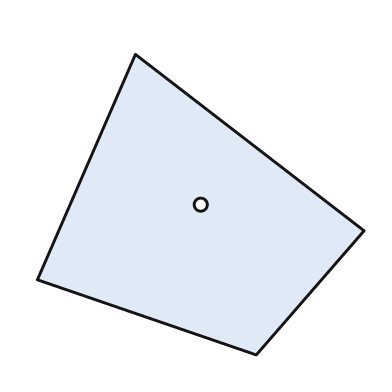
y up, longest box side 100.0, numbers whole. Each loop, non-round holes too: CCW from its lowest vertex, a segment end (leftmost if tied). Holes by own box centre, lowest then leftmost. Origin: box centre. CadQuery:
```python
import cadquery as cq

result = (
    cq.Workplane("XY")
    .moveTo(17.0, -46.0)
    .lineTo(50.0, -8.0)
    .lineTo(-20.0, 46.0)
    .lineTo(-50.0, -23.0)
    .close()
    .moveTo(0.0, 0.0)
    .circle(2.0)
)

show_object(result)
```